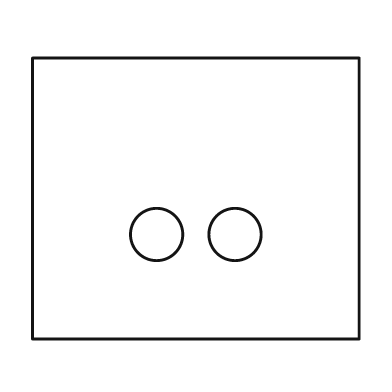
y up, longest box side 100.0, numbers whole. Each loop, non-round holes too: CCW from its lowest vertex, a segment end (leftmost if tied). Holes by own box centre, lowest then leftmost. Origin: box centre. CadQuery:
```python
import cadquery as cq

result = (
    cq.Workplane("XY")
    .moveTo(-50.0, -43.0)
    .lineTo(50.0, -43.0)
    .lineTo(50.0, 43.0)
    .lineTo(-50.0, 43.0)
    .close()
    .moveTo(-12.0, -11.0)
    .circle(8.0)
    .moveTo(12.0, -11.0)
    .circle(8.0)
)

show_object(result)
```